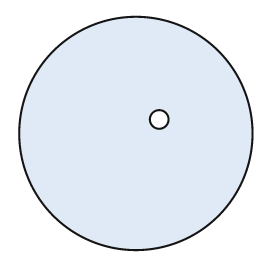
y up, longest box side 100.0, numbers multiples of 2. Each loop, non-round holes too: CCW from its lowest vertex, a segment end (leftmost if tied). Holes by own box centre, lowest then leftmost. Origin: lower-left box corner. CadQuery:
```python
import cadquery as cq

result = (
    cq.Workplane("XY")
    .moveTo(50.0, 50.0)
    .circle(50.0)
    .moveTo(60.0, 56.0)
    .circle(4.0)
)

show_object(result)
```